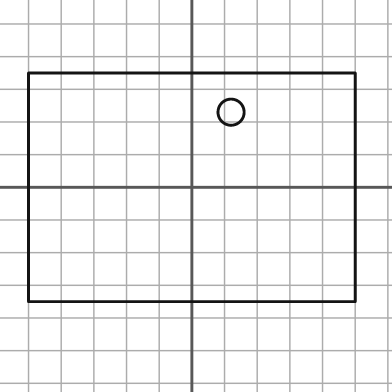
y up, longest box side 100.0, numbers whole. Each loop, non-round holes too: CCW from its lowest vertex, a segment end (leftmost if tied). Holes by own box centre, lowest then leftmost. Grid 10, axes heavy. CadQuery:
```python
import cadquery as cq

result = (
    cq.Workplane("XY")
    .moveTo(-50.0, -35.0)
    .lineTo(50.0, -35.0)
    .lineTo(50.0, 35.0)
    .lineTo(-50.0, 35.0)
    .close()
    .moveTo(12.0, 23.0)
    .circle(4.0)
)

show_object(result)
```